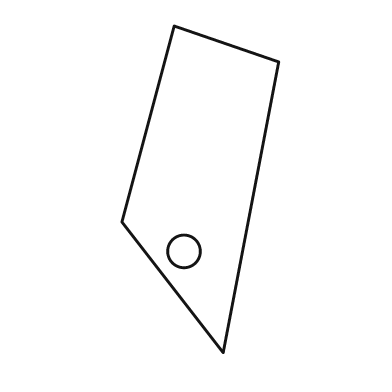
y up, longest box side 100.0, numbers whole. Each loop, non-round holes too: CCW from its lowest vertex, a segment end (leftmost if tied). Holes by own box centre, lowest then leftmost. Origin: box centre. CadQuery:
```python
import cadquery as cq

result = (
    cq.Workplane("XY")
    .moveTo(7.0, -50.0)
    .lineTo(24.0, 39.0)
    .lineTo(-8.0, 50.0)
    .lineTo(-24.0, -10.0)
    .close()
    .moveTo(-5.0, -19.0)
    .circle(5.0)
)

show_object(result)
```